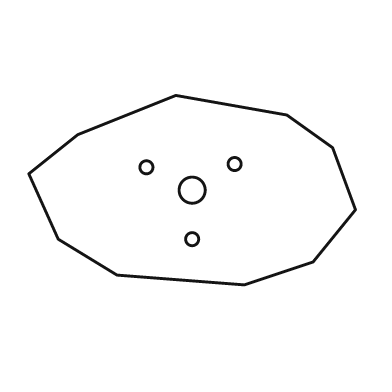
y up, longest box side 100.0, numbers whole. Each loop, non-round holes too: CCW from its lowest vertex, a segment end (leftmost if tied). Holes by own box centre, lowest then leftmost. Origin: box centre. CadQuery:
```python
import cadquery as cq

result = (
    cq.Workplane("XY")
    .moveTo(16.0, -29.0)
    .lineTo(37.0, -22.0)
    .lineTo(50.0, -6.0)
    .lineTo(43.0, 13.0)
    .lineTo(29.0, 23.0)
    .lineTo(-5.0, 29.0)
    .lineTo(-35.0, 17.0)
    .lineTo(-50.0, 5.0)
    .lineTo(-41.0, -15.0)
    .lineTo(-23.0, -26.0)
    .close()
    .moveTo(0.0, -15.0)
    .circle(2.0)
    .moveTo(0.0, 0.0)
    .circle(4.0)
    .moveTo(-14.0, 7.0)
    .circle(2.0)
    .moveTo(13.0, 8.0)
    .circle(2.0)
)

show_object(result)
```